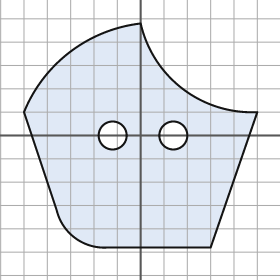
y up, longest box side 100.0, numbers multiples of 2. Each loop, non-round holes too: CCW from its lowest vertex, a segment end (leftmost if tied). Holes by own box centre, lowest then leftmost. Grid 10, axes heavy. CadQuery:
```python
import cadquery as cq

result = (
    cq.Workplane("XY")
    .moveTo(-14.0, -48.0)
    .lineTo(30.0, -48.0)
    .lineTo(50.0, 10.0)
    .threePointArc((18.0, 20.0), (0.0, 48.0))
    .threePointArc((-30.0, 36.0), (-50.0, 10.0))
    .lineTo(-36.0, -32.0)
    .threePointArc((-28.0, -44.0), (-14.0, -48.0))
    .close()
    .moveTo(-12.0, 0.0)
    .circle(6.0)
    .moveTo(14.0, 0.0)
    .circle(6.0)
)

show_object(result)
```